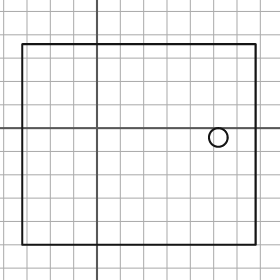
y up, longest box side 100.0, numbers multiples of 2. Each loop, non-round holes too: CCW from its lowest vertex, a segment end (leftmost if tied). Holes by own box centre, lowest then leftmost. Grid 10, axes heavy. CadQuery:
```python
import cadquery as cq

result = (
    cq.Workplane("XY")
    .moveTo(-32.0, -50.0)
    .lineTo(68.0, -50.0)
    .lineTo(68.0, 36.0)
    .lineTo(-32.0, 36.0)
    .close()
    .moveTo(52.0, -4.0)
    .circle(4.0)
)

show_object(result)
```